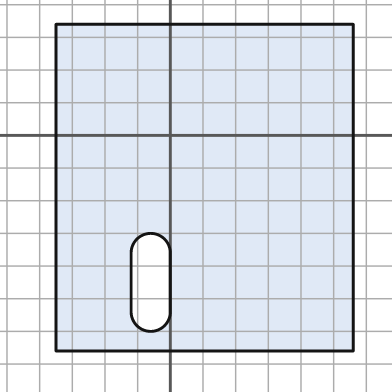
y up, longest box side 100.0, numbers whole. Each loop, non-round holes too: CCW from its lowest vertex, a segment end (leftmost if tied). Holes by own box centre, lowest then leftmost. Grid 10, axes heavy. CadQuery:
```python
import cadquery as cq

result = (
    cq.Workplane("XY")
    .moveTo(-35.0, -66.0)
    .lineTo(56.0, -66.0)
    .lineTo(56.0, 34.0)
    .lineTo(-35.0, 34.0)
    .close()
    .moveTo(-12.0, -54.0)
    .threePointArc((-6.0, -60.0), (0.0, -54.0))
    .lineTo(0.0, -36.0)
    .threePointArc((-6.0, -30.0), (-12.0, -36.0))
    .close()
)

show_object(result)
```